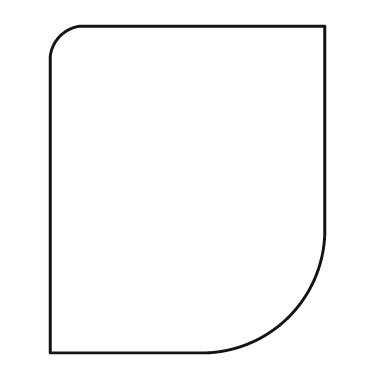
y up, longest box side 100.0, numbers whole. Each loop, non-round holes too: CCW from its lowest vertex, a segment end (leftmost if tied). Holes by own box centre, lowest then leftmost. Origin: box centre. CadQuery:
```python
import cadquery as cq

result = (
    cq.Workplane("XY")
    .moveTo(-42.0, -50.0)
    .lineTo(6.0, -50.0)
    .threePointArc((31.0, -39.0), (42.0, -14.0))
    .lineTo(42.0, 50.0)
    .lineTo(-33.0, 50.0)
    .threePointArc((-39.0, 47.0), (-42.0, 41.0))
    .close()
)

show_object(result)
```